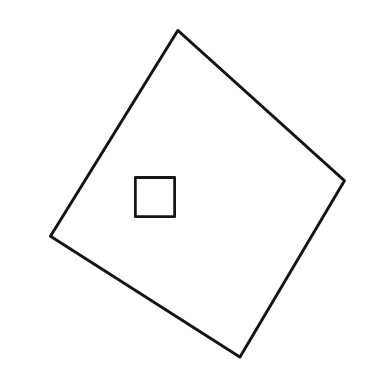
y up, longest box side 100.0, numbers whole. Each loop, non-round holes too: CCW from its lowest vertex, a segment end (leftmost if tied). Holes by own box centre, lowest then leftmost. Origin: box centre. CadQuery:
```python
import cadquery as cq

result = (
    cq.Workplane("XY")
    .moveTo(13.0, -50.0)
    .lineTo(45.0, 4.0)
    .lineTo(-6.0, 50.0)
    .lineTo(-45.0, -13.0)
    .close()
    .moveTo(-19.0, -7.0)
    .lineTo(-7.0, -7.0)
    .lineTo(-7.0, 5.0)
    .lineTo(-19.0, 5.0)
    .close()
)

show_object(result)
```